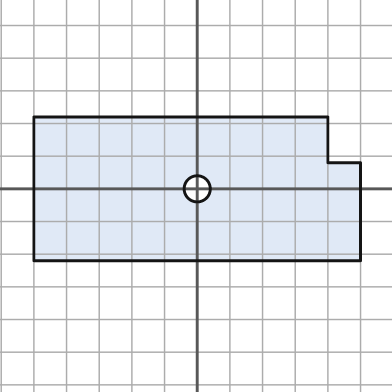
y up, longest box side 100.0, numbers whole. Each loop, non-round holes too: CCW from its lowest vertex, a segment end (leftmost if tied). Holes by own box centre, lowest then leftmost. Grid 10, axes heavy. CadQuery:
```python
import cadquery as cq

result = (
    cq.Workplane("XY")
    .moveTo(-50.0, -22.0)
    .lineTo(50.0, -22.0)
    .lineTo(50.0, 8.0)
    .lineTo(40.0, 8.0)
    .lineTo(40.0, 22.0)
    .lineTo(-50.0, 22.0)
    .close()
    .moveTo(0.0, 0.0)
    .circle(4.0)
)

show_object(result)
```